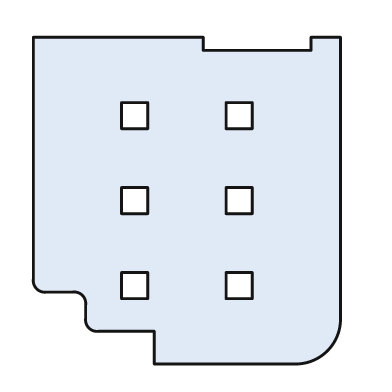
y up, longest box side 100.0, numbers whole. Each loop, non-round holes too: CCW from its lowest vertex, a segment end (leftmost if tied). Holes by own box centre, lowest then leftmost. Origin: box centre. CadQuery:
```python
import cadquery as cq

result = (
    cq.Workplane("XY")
    .moveTo(-10.0, -50.0)
    .lineTo(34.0, -50.0)
    .threePointArc((43.0, -46.0), (47.0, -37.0))
    .lineTo(47.0, 50.0)
    .lineTo(38.0, 50.0)
    .lineTo(38.0, 46.0)
    .lineTo(5.0, 46.0)
    .lineTo(5.0, 50.0)
    .lineTo(-47.0, 50.0)
    .lineTo(-47.0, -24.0)
    .threePointArc((-46.0, -27.0), (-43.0, -28.0))
    .lineTo(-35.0, -28.0)
    .threePointArc((-32.0, -29.0), (-31.0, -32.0))
    .lineTo(-31.0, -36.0)
    .threePointArc((-30.0, -39.0), (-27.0, -40.0))
    .lineTo(-10.0, -40.0)
    .close()
    .moveTo(-20.0, -30.0)
    .lineTo(-12.0, -30.0)
    .lineTo(-12.0, -22.0)
    .lineTo(-20.0, -22.0)
    .close()
    .moveTo(12.0, -30.0)
    .lineTo(20.0, -30.0)
    .lineTo(20.0, -22.0)
    .lineTo(12.0, -22.0)
    .close()
    .moveTo(-20.0, -4.0)
    .lineTo(-12.0, -4.0)
    .lineTo(-12.0, 4.0)
    .lineTo(-20.0, 4.0)
    .close()
    .moveTo(12.0, -4.0)
    .lineTo(20.0, -4.0)
    .lineTo(20.0, 4.0)
    .lineTo(12.0, 4.0)
    .close()
    .moveTo(-20.0, 22.0)
    .lineTo(-12.0, 22.0)
    .lineTo(-12.0, 30.0)
    .lineTo(-20.0, 30.0)
    .close()
    .moveTo(12.0, 22.0)
    .lineTo(20.0, 22.0)
    .lineTo(20.0, 30.0)
    .lineTo(12.0, 30.0)
    .close()
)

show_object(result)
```